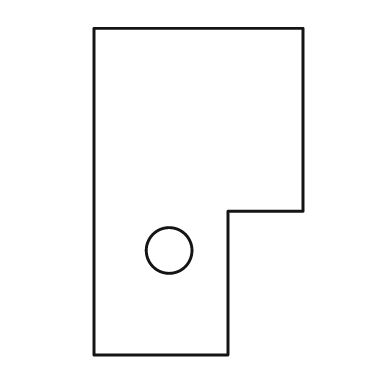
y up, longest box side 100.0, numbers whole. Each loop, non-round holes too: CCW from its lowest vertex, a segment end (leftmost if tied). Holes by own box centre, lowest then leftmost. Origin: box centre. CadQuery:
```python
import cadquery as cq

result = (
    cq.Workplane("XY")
    .moveTo(-32.0, -50.0)
    .lineTo(9.0, -50.0)
    .lineTo(9.0, -6.0)
    .lineTo(32.0, -6.0)
    .lineTo(32.0, 50.0)
    .lineTo(-32.0, 50.0)
    .close()
    .moveTo(-9.0, -18.0)
    .circle(7.0)
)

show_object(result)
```